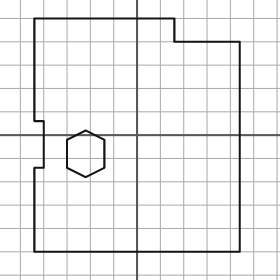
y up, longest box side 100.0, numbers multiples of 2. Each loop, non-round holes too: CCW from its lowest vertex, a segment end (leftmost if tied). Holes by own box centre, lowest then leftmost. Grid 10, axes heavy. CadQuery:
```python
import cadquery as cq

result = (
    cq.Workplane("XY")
    .moveTo(-44.0, -50.0)
    .lineTo(44.0, -50.0)
    .lineTo(44.0, 40.0)
    .lineTo(16.0, 40.0)
    .lineTo(16.0, 50.0)
    .lineTo(-44.0, 50.0)
    .lineTo(-44.0, 6.0)
    .lineTo(-40.0, 6.0)
    .lineTo(-40.0, -14.0)
    .lineTo(-44.0, -14.0)
    .close()
    .moveTo(-22.0, -18.0)
    .lineTo(-14.0, -14.0)
    .lineTo(-14.0, -2.0)
    .lineTo(-22.0, 2.0)
    .lineTo(-30.0, -2.0)
    .lineTo(-30.0, -14.0)
    .close()
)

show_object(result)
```